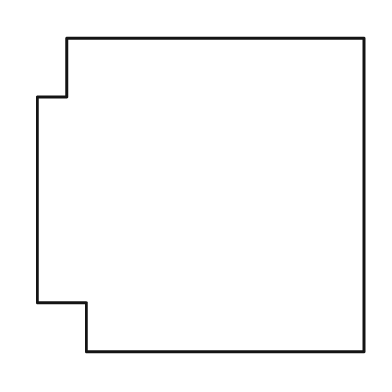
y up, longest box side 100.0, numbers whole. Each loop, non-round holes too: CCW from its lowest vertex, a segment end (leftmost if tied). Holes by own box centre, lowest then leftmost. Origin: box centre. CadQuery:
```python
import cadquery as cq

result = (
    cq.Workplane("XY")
    .moveTo(-35.0, -48.0)
    .lineTo(50.0, -48.0)
    .lineTo(50.0, 48.0)
    .lineTo(-41.0, 48.0)
    .lineTo(-41.0, 30.0)
    .lineTo(-50.0, 30.0)
    .lineTo(-50.0, -33.0)
    .lineTo(-35.0, -33.0)
    .close()
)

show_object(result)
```